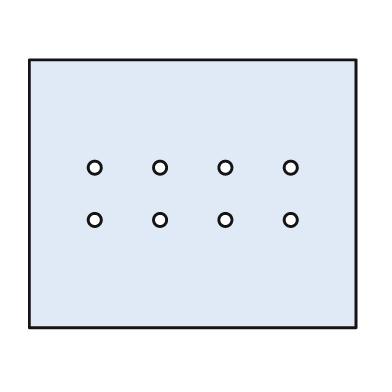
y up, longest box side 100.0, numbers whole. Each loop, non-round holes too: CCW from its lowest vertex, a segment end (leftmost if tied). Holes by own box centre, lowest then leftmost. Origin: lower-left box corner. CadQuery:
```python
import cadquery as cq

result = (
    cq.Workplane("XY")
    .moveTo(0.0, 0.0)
    .lineTo(100.0, 0.0)
    .lineTo(100.0, 82.0)
    .lineTo(0.0, 82.0)
    .close()
    .moveTo(20.0, 33.0)
    .circle(2.0)
    .moveTo(40.0, 33.0)
    .circle(2.0)
    .moveTo(60.0, 33.0)
    .circle(2.0)
    .moveTo(80.0, 33.0)
    .circle(2.0)
    .moveTo(20.0, 49.0)
    .circle(2.0)
    .moveTo(40.0, 49.0)
    .circle(2.0)
    .moveTo(60.0, 49.0)
    .circle(2.0)
    .moveTo(80.0, 49.0)
    .circle(2.0)
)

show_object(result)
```